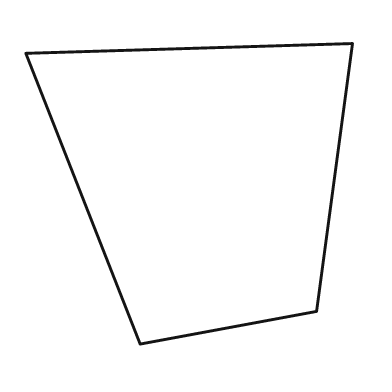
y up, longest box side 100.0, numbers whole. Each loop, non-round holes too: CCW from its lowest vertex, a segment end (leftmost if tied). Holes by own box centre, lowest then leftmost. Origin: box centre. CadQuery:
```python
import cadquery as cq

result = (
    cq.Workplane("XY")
    .moveTo(-15.0, -46.0)
    .lineTo(39.0, -36.0)
    .lineTo(50.0, 46.0)
    .lineTo(-50.0, 43.0)
    .close()
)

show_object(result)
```